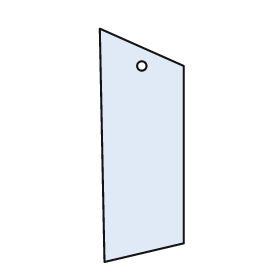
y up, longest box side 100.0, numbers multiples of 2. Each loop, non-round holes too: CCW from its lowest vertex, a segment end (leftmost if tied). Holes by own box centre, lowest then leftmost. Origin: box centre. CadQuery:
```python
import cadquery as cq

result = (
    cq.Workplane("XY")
    .moveTo(-16.0, -50.0)
    .lineTo(18.0, -42.0)
    .lineTo(18.0, 34.0)
    .lineTo(-18.0, 50.0)
    .close()
    .moveTo(0.0, 34.0)
    .circle(2.0)
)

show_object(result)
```